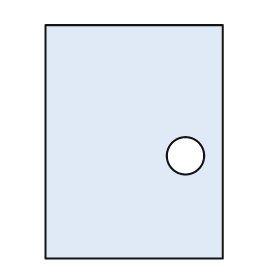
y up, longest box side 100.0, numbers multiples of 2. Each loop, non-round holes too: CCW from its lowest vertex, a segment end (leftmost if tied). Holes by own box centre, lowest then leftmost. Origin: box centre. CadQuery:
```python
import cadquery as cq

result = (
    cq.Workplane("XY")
    .moveTo(-38.0, -50.0)
    .lineTo(38.0, -50.0)
    .lineTo(38.0, 50.0)
    .lineTo(-38.0, 50.0)
    .close()
    .moveTo(22.0, -6.0)
    .circle(8.0)
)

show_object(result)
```